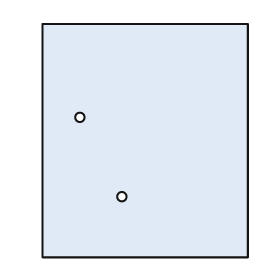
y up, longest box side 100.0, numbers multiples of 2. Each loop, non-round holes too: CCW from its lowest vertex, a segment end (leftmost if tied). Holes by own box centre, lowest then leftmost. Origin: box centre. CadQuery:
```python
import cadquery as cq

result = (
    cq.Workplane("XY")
    .moveTo(-44.0, -50.0)
    .lineTo(44.0, -50.0)
    .lineTo(44.0, 50.0)
    .lineTo(-44.0, 50.0)
    .close()
    .moveTo(-10.0, -24.0)
    .circle(2.0)
    .moveTo(-28.0, 10.0)
    .circle(2.0)
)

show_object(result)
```